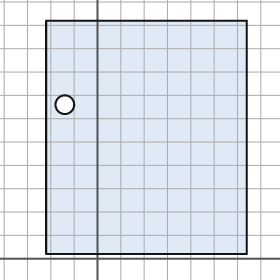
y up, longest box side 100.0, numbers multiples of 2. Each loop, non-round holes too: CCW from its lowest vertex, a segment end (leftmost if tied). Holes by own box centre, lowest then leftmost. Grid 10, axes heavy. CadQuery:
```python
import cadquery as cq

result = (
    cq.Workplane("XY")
    .moveTo(-22.0, 2.0)
    .lineTo(64.0, 2.0)
    .lineTo(64.0, 102.0)
    .lineTo(-22.0, 102.0)
    .close()
    .moveTo(-14.0, 66.0)
    .circle(4.0)
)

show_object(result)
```